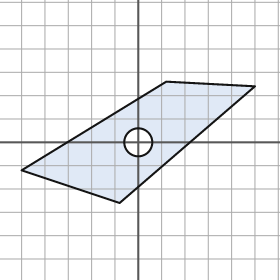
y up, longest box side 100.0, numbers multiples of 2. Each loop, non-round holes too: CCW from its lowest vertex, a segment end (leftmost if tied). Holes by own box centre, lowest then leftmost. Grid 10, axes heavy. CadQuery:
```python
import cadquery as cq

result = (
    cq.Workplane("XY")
    .moveTo(-8.0, -26.0)
    .lineTo(50.0, 24.0)
    .lineTo(12.0, 26.0)
    .lineTo(-50.0, -12.0)
    .close()
    .moveTo(0.0, 0.0)
    .circle(6.0)
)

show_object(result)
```